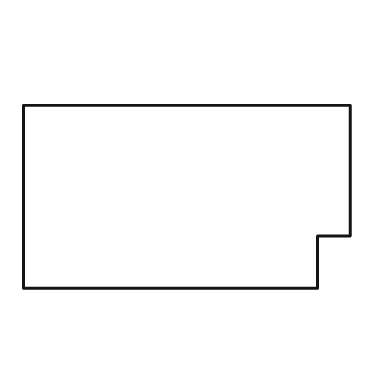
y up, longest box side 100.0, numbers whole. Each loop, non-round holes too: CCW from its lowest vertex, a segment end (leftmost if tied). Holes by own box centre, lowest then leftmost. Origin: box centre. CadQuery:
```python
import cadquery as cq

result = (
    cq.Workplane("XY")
    .moveTo(-50.0, -28.0)
    .lineTo(40.0, -28.0)
    .lineTo(40.0, -12.0)
    .lineTo(50.0, -12.0)
    .lineTo(50.0, 28.0)
    .lineTo(-50.0, 28.0)
    .close()
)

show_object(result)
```